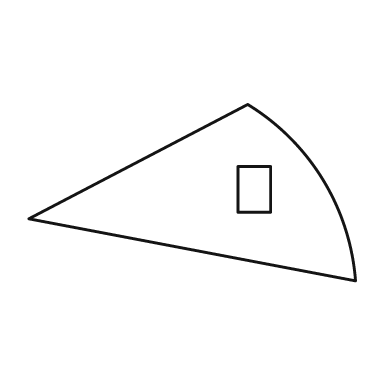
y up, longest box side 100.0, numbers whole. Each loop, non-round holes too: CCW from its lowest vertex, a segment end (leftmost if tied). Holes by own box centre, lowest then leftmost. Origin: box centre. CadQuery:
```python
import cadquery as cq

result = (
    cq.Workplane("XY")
    .moveTo(50.0, -27.0)
    .threePointArc((40.0, 4.0), (17.0, 27.0))
    .lineTo(-50.0, -8.0)
    .close()
    .moveTo(14.0, -6.0)
    .lineTo(24.0, -6.0)
    .lineTo(24.0, 8.0)
    .lineTo(14.0, 8.0)
    .close()
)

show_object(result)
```